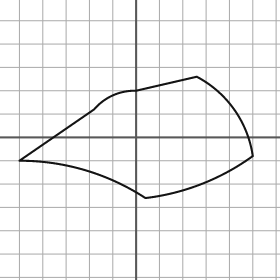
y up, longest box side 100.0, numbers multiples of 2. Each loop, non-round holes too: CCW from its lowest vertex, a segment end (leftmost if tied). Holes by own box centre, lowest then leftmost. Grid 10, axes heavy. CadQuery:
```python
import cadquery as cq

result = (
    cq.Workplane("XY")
    .moveTo(4.0, -26.0)
    .threePointArc((28.0, -20.0), (50.0, -8.0))
    .threePointArc((42.0, 12.0), (26.0, 26.0))
    .lineTo(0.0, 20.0)
    .threePointArc((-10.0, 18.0), (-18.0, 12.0))
    .lineTo(-50.0, -10.0)
    .threePointArc((-22.0, -14.0), (4.0, -26.0))
    .close()
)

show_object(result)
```